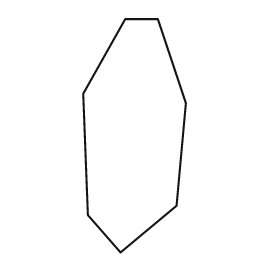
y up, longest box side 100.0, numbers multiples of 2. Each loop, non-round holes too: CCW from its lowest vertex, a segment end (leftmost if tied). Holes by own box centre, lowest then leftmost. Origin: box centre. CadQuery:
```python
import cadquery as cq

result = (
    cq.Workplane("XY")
    .moveTo(-6.0, -50.0)
    .lineTo(18.0, -30.0)
    .lineTo(22.0, 14.0)
    .lineTo(10.0, 50.0)
    .lineTo(-4.0, 50.0)
    .lineTo(-22.0, 18.0)
    .lineTo(-20.0, -34.0)
    .close()
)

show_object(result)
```